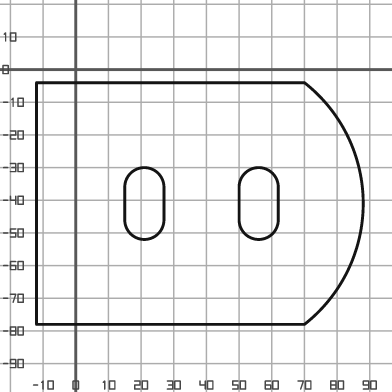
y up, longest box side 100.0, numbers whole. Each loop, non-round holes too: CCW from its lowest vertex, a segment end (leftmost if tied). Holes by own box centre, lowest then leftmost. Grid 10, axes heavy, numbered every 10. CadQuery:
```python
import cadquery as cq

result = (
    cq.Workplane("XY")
    .moveTo(-12.0, -78.0)
    .lineTo(70.0, -78.0)
    .threePointArc((88.0, -41.0), (70.0, -4.0))
    .lineTo(-12.0, -4.0)
    .close()
    .moveTo(15.0, -46.0)
    .threePointArc((21.0, -52.0), (27.0, -46.0))
    .lineTo(27.0, -36.0)
    .threePointArc((21.0, -30.0), (15.0, -36.0))
    .close()
    .moveTo(50.0, -46.0)
    .threePointArc((56.0, -52.0), (62.0, -46.0))
    .lineTo(62.0, -36.0)
    .threePointArc((56.0, -30.0), (50.0, -36.0))
    .close()
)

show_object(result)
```